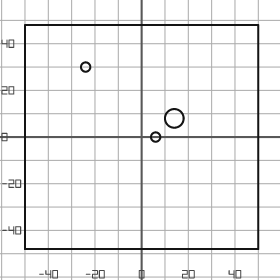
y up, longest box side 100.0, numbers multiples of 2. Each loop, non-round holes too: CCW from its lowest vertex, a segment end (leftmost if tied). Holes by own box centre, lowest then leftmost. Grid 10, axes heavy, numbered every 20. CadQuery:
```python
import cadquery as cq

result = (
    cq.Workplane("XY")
    .moveTo(-50.0, -48.0)
    .lineTo(50.0, -48.0)
    .lineTo(50.0, 48.0)
    .lineTo(-50.0, 48.0)
    .close()
    .moveTo(6.0, 0.0)
    .circle(2.0)
    .moveTo(14.0, 8.0)
    .circle(4.0)
    .moveTo(-24.0, 30.0)
    .circle(2.0)
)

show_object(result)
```